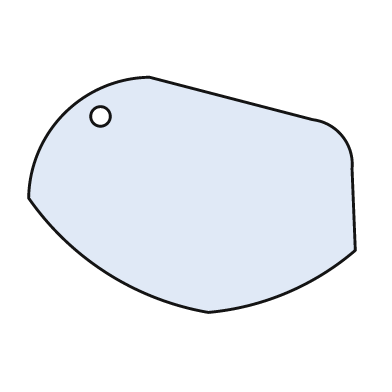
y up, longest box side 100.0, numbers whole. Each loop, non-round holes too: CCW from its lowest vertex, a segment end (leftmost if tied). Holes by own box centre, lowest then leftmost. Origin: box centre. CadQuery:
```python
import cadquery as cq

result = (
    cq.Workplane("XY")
    .moveTo(5.0, -36.0)
    .threePointArc((29.0, -30.0), (50.0, -17.0))
    .lineTo(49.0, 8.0)
    .threePointArc((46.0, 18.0), (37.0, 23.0))
    .lineTo(-13.0, 36.0)
    .threePointArc((-39.0, 25.0), (-50.0, -1.0))
    .threePointArc((-26.0, -24.0), (5.0, -36.0))
    .close()
    .moveTo(-28.0, 24.0)
    .circle(3.0)
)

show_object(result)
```